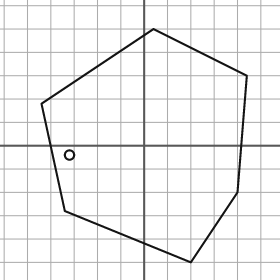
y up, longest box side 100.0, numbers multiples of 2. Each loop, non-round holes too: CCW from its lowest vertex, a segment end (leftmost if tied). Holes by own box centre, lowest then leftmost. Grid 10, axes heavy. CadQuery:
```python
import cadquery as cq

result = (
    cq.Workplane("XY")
    .moveTo(20.0, -50.0)
    .lineTo(40.0, -20.0)
    .lineTo(44.0, 30.0)
    .lineTo(4.0, 50.0)
    .lineTo(-44.0, 18.0)
    .lineTo(-34.0, -28.0)
    .close()
    .moveTo(-32.0, -4.0)
    .circle(2.0)
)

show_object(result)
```